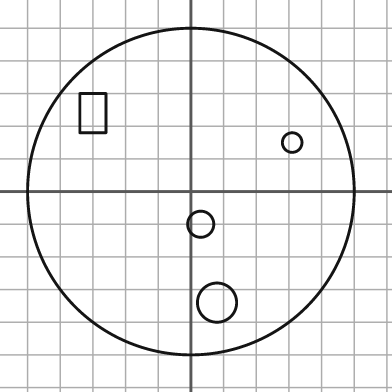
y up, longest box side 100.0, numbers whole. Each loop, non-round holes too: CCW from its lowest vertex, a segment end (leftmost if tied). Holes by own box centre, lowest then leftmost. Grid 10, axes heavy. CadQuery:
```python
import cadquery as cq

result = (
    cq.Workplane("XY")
    .moveTo(0.0, 0.0)
    .circle(50.0)
    .moveTo(8.0, -34.0)
    .circle(6.0)
    .moveTo(3.0, -10.0)
    .circle(4.0)
    .moveTo(31.0, 15.0)
    .circle(3.0)
    .moveTo(-34.0, 18.0)
    .lineTo(-26.0, 18.0)
    .lineTo(-26.0, 30.0)
    .lineTo(-34.0, 30.0)
    .close()
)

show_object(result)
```